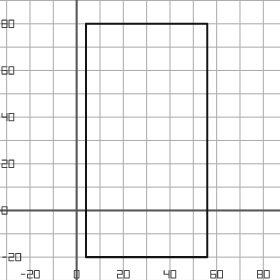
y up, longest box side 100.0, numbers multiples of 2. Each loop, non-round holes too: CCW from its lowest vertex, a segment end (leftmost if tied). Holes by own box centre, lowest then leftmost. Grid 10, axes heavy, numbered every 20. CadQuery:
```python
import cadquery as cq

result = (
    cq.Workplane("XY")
    .moveTo(4.0, -20.0)
    .lineTo(56.0, -20.0)
    .lineTo(56.0, 80.0)
    .lineTo(4.0, 80.0)
    .close()
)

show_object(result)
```